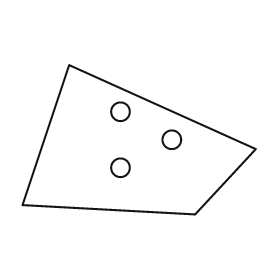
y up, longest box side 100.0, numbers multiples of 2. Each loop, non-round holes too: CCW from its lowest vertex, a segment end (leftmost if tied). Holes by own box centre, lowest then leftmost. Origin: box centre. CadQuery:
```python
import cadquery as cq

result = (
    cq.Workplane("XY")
    .moveTo(24.0, -32.0)
    .lineTo(50.0, -4.0)
    .lineTo(-30.0, 32.0)
    .lineTo(-50.0, -28.0)
    .close()
    .moveTo(-8.0, -12.0)
    .circle(4.0)
    .moveTo(14.0, 0.0)
    .circle(4.0)
    .moveTo(-8.0, 12.0)
    .circle(4.0)
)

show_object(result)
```